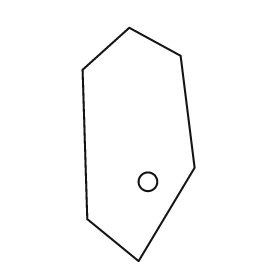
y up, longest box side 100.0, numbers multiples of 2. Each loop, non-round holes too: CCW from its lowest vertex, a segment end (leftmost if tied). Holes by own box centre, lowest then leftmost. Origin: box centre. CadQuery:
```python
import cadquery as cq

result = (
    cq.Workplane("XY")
    .moveTo(0.0, -50.0)
    .lineTo(24.0, -10.0)
    .lineTo(18.0, 38.0)
    .lineTo(-4.0, 50.0)
    .lineTo(-24.0, 32.0)
    .lineTo(-22.0, -32.0)
    .close()
    .moveTo(4.0, -16.0)
    .circle(4.0)
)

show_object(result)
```